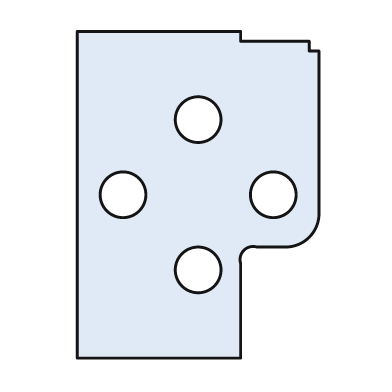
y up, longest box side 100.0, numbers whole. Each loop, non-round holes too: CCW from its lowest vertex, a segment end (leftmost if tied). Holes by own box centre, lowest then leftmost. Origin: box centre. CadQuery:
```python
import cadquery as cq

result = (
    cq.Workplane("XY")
    .moveTo(-37.0, -50.0)
    .lineTo(13.0, -50.0)
    .lineTo(13.0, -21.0)
    .threePointArc((14.0, -17.0), (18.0, -16.0))
    .lineTo(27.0, -16.0)
    .threePointArc((34.0, -13.0), (37.0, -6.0))
    .lineTo(37.0, 44.0)
    .lineTo(34.0, 44.0)
    .lineTo(34.0, 47.0)
    .lineTo(13.0, 47.0)
    .lineTo(13.0, 50.0)
    .lineTo(-37.0, 50.0)
    .close()
    .moveTo(0.0, -23.0)
    .circle(7.0)
    .moveTo(-23.0, 0.0)
    .circle(7.0)
    .moveTo(23.0, 0.0)
    .circle(7.0)
    .moveTo(0.0, 23.0)
    .circle(7.0)
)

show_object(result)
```